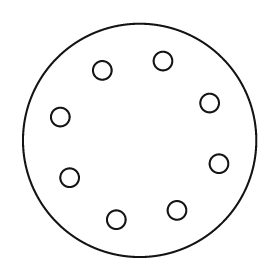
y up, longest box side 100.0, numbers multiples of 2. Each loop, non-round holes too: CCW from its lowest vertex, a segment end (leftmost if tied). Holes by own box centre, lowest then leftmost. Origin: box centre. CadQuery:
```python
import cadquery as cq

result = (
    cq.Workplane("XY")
    .moveTo(0.0, 0.0)
    .circle(50.0)
    .moveTo(-10.0, -34.0)
    .circle(4.0)
    .moveTo(16.0, -30.0)
    .circle(4.0)
    .moveTo(-30.0, -16.0)
    .circle(4.0)
    .moveTo(34.0, -10.0)
    .circle(4.0)
    .moveTo(-34.0, 10.0)
    .circle(4.0)
    .moveTo(30.0, 16.0)
    .circle(4.0)
    .moveTo(-16.0, 30.0)
    .circle(4.0)
    .moveTo(10.0, 34.0)
    .circle(4.0)
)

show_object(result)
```